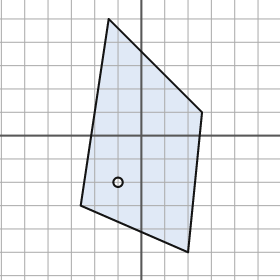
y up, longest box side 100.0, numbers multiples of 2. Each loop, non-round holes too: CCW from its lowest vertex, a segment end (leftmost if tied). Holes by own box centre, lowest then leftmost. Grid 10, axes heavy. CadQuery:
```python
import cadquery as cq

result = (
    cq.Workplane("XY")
    .moveTo(20.0, -50.0)
    .lineTo(26.0, 10.0)
    .lineTo(-14.0, 50.0)
    .lineTo(-26.0, -30.0)
    .close()
    .moveTo(-10.0, -20.0)
    .circle(2.0)
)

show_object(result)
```